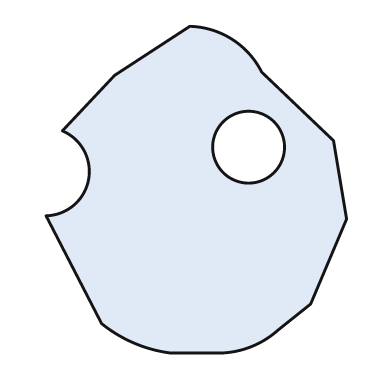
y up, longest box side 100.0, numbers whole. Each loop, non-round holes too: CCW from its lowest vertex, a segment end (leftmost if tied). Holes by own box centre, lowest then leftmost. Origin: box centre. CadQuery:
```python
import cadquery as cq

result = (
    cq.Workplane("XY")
    .moveTo(-8.0, -50.0)
    .lineTo(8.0, -50.0)
    .threePointArc((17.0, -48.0), (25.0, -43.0))
    .lineTo(35.0, -35.0)
    .lineTo(46.0, -9.0)
    .lineTo(42.0, 15.0)
    .lineTo(20.0, 36.0)
    .threePointArc((11.0, 46.0), (-2.0, 50.0))
    .lineTo(-25.0, 35.0)
    .lineTo(-41.0, 18.0)
    .threePointArc((-33.0, 3.0), (-46.0, -8.0))
    .lineTo(-29.0, -41.0)
    .threePointArc((-19.0, -47.0), (-8.0, -50.0))
    .close()
    .moveTo(16.0, 13.0)
    .circle(11.0)
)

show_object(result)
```